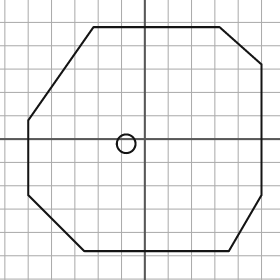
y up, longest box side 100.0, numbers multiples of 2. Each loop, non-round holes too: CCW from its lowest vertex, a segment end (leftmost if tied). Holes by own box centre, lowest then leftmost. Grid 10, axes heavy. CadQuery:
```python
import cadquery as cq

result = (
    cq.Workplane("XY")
    .moveTo(-26.0, -48.0)
    .lineTo(36.0, -48.0)
    .lineTo(50.0, -24.0)
    .lineTo(50.0, 32.0)
    .lineTo(32.0, 48.0)
    .lineTo(-22.0, 48.0)
    .lineTo(-50.0, 8.0)
    .lineTo(-50.0, -24.0)
    .close()
    .moveTo(-8.0, -2.0)
    .circle(4.0)
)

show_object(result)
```